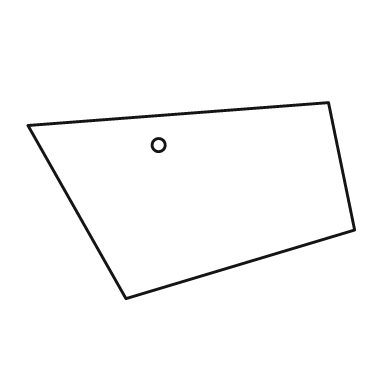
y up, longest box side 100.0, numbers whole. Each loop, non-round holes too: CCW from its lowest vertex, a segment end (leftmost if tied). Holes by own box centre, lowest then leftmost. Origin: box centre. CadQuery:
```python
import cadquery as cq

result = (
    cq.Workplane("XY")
    .moveTo(-20.0, -30.0)
    .lineTo(50.0, -9.0)
    .lineTo(42.0, 30.0)
    .lineTo(-50.0, 23.0)
    .close()
    .moveTo(-10.0, 17.0)
    .circle(2.0)
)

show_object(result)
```